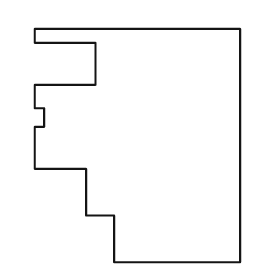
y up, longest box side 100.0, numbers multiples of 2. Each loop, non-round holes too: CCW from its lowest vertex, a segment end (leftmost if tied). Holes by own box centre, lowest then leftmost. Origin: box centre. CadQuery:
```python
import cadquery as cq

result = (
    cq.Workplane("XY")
    .moveTo(-10.0, -50.0)
    .lineTo(44.0, -50.0)
    .lineTo(44.0, 50.0)
    .lineTo(-44.0, 50.0)
    .lineTo(-44.0, 44.0)
    .lineTo(-18.0, 44.0)
    .lineTo(-18.0, 26.0)
    .lineTo(-44.0, 26.0)
    .lineTo(-44.0, 16.0)
    .lineTo(-40.0, 16.0)
    .lineTo(-40.0, 8.0)
    .lineTo(-44.0, 8.0)
    .lineTo(-44.0, -10.0)
    .lineTo(-22.0, -10.0)
    .lineTo(-22.0, -30.0)
    .lineTo(-10.0, -30.0)
    .close()
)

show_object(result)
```